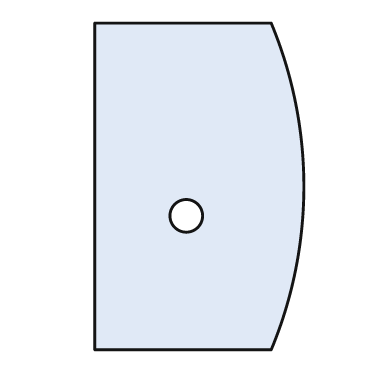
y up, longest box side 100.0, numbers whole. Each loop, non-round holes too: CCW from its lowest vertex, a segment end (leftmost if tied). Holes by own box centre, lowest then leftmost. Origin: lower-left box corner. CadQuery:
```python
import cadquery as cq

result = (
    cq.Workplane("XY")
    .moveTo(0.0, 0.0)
    .lineTo(54.0, 0.0)
    .threePointArc((64.0, 50.0), (54.0, 100.0))
    .lineTo(0.0, 100.0)
    .close()
    .moveTo(28.0, 41.0)
    .circle(5.0)
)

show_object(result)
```